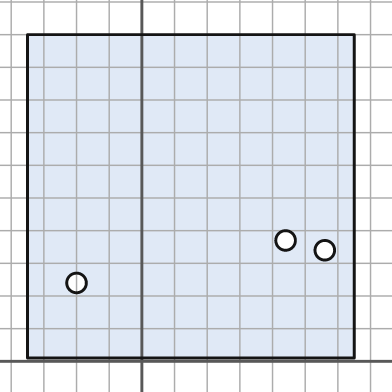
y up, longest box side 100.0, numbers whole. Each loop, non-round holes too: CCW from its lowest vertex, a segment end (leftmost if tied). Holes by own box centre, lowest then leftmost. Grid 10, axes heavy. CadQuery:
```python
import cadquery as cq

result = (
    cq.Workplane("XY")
    .moveTo(-35.0, 1.0)
    .lineTo(65.0, 1.0)
    .lineTo(65.0, 100.0)
    .lineTo(-35.0, 100.0)
    .close()
    .moveTo(-20.0, 24.0)
    .circle(3.0)
    .moveTo(56.0, 34.0)
    .circle(3.0)
    .moveTo(44.0, 37.0)
    .circle(3.0)
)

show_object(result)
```